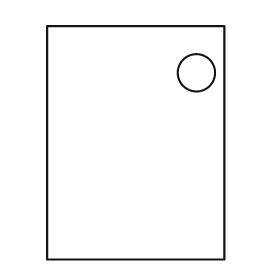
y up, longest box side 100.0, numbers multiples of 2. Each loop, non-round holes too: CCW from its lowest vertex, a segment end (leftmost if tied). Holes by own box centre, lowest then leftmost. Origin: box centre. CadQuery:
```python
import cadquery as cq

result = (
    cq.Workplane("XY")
    .moveTo(-38.0, -50.0)
    .lineTo(38.0, -50.0)
    .lineTo(38.0, 50.0)
    .lineTo(-38.0, 50.0)
    .close()
    .moveTo(26.0, 30.0)
    .circle(8.0)
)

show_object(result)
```